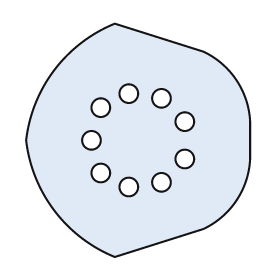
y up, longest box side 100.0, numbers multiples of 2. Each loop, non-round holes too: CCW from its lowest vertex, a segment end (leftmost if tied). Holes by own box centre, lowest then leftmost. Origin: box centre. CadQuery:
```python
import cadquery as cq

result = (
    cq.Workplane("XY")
    .moveTo(-10.0, -50.0)
    .lineTo(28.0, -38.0)
    .threePointArc((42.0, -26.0), (48.0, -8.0))
    .lineTo(48.0, 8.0)
    .threePointArc((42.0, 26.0), (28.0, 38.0))
    .lineTo(-10.0, 50.0)
    .threePointArc((-36.0, 30.0), (-48.0, 0.0))
    .threePointArc((-36.0, -30.0), (-10.0, -50.0))
    .close()
    .moveTo(-4.0, -20.0)
    .circle(4.0)
    .moveTo(10.0, -18.0)
    .circle(4.0)
    .moveTo(-16.0, -14.0)
    .circle(4.0)
    .moveTo(20.0, -8.0)
    .circle(4.0)
    .moveTo(-20.0, 0.0)
    .circle(4.0)
    .moveTo(20.0, 8.0)
    .circle(4.0)
    .moveTo(-16.0, 14.0)
    .circle(4.0)
    .moveTo(10.0, 18.0)
    .circle(4.0)
    .moveTo(-4.0, 20.0)
    .circle(4.0)
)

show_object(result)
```